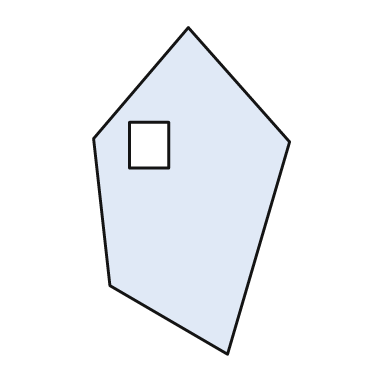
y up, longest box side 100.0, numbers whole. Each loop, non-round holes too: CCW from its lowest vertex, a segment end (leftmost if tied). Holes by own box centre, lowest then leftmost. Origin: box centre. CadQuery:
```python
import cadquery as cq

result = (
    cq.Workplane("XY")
    .moveTo(11.0, -50.0)
    .lineTo(30.0, 15.0)
    .lineTo(-1.0, 50.0)
    .lineTo(-30.0, 16.0)
    .lineTo(-25.0, -29.0)
    .close()
    .moveTo(-19.0, 7.0)
    .lineTo(-7.0, 7.0)
    .lineTo(-7.0, 21.0)
    .lineTo(-19.0, 21.0)
    .close()
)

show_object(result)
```